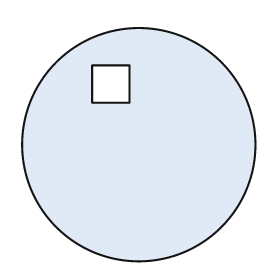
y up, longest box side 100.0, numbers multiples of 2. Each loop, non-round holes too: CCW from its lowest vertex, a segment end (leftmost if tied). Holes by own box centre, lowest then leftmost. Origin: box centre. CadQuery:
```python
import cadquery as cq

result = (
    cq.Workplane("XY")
    .moveTo(0.0, 0.0)
    .circle(50.0)
    .moveTo(-20.0, 18.0)
    .lineTo(-4.0, 18.0)
    .lineTo(-4.0, 34.0)
    .lineTo(-20.0, 34.0)
    .close()
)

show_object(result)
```